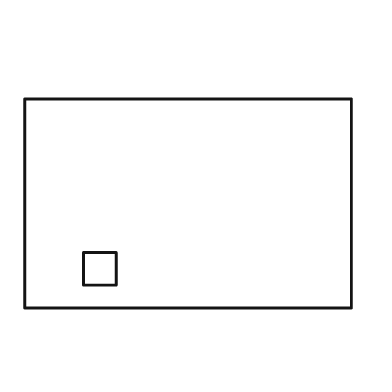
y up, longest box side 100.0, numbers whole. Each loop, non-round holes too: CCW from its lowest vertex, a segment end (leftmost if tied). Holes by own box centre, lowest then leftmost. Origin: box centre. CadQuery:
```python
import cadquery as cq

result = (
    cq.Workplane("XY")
    .moveTo(-50.0, -32.0)
    .lineTo(50.0, -32.0)
    .lineTo(50.0, 32.0)
    .lineTo(-50.0, 32.0)
    .close()
    .moveTo(-32.0, -25.0)
    .lineTo(-22.0, -25.0)
    .lineTo(-22.0, -15.0)
    .lineTo(-32.0, -15.0)
    .close()
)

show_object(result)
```